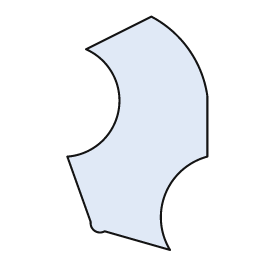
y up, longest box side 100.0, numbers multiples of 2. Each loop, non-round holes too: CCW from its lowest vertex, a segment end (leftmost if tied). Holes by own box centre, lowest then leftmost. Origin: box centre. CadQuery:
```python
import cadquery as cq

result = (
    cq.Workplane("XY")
    .moveTo(14.0, -50.0)
    .threePointArc((12.0, -26.0), (30.0, -10.0))
    .lineTo(30.0, 16.0)
    .threePointArc((22.0, 36.0), (6.0, 50.0))
    .lineTo(-22.0, 36.0)
    .threePointArc((-8.0, 10.0), (-30.0, -10.0))
    .lineTo(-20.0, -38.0)
    .threePointArc((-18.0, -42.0), (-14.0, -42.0))
    .close()
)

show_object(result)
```